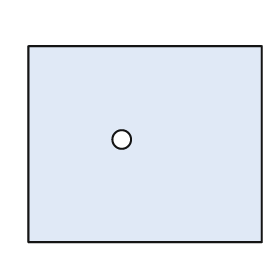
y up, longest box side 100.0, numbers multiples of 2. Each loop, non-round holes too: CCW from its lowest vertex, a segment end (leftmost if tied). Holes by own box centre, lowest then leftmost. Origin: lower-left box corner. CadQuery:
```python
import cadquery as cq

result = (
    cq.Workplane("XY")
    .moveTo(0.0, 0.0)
    .lineTo(100.0, 0.0)
    .lineTo(100.0, 84.0)
    .lineTo(0.0, 84.0)
    .close()
    .moveTo(40.0, 44.0)
    .circle(4.0)
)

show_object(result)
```